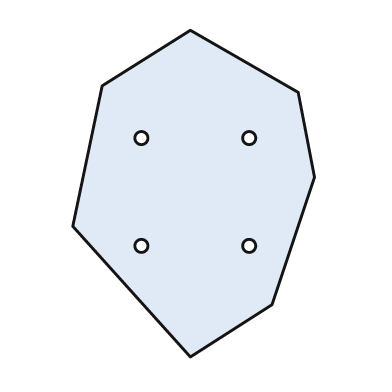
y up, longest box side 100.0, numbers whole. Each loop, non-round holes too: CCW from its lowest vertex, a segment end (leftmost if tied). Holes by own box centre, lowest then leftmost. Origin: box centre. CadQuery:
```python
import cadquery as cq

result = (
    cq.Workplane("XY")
    .moveTo(-1.0, -50.0)
    .lineTo(24.0, -34.0)
    .lineTo(37.0, 5.0)
    .lineTo(32.0, 31.0)
    .lineTo(-1.0, 50.0)
    .lineTo(-28.0, 33.0)
    .lineTo(-37.0, -10.0)
    .close()
    .moveTo(-16.0, -16.0)
    .circle(2.0)
    .moveTo(17.0, -16.0)
    .circle(2.0)
    .moveTo(-16.0, 17.0)
    .circle(2.0)
    .moveTo(17.0, 17.0)
    .circle(2.0)
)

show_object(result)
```